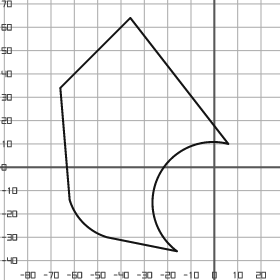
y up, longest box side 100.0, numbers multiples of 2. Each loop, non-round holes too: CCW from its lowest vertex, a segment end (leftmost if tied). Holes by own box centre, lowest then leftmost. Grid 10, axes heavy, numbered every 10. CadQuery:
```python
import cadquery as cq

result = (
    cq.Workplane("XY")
    .moveTo(-16.0, -36.0)
    .threePointArc((-24.0, -4.0), (6.0, 10.0))
    .lineTo(-36.0, 64.0)
    .lineTo(-66.0, 34.0)
    .lineTo(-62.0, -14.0)
    .threePointArc((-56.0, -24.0), (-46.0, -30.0))
    .close()
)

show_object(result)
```